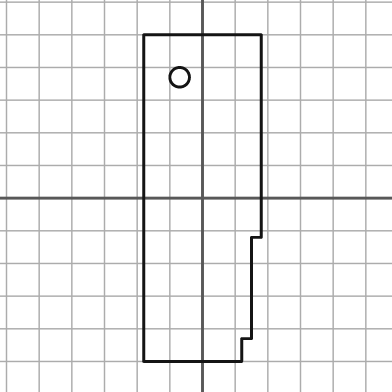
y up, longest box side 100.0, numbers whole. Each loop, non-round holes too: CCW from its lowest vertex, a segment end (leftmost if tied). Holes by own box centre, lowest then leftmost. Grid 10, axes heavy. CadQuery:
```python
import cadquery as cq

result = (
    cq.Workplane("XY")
    .moveTo(-18.0, -50.0)
    .lineTo(12.0, -50.0)
    .lineTo(12.0, -43.0)
    .lineTo(15.0, -43.0)
    .lineTo(15.0, -12.0)
    .lineTo(18.0, -12.0)
    .lineTo(18.0, 50.0)
    .lineTo(-18.0, 50.0)
    .close()
    .moveTo(-7.0, 37.0)
    .circle(3.0)
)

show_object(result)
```